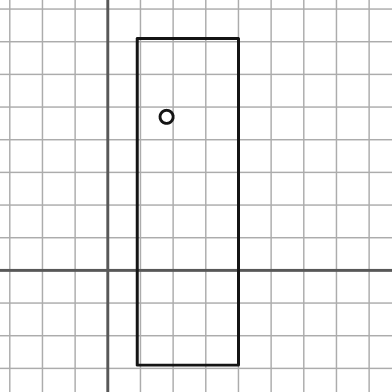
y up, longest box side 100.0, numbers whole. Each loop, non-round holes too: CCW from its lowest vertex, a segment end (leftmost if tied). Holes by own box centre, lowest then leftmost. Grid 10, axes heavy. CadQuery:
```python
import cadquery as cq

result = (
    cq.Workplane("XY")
    .moveTo(9.0, -29.0)
    .lineTo(40.0, -29.0)
    .lineTo(40.0, 71.0)
    .lineTo(9.0, 71.0)
    .close()
    .moveTo(18.0, 47.0)
    .circle(2.0)
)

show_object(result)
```